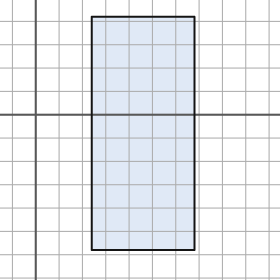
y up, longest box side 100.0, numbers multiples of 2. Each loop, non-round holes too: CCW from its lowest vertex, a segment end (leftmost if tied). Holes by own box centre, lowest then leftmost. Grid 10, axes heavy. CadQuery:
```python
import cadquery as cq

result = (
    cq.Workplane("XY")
    .moveTo(24.0, -58.0)
    .lineTo(68.0, -58.0)
    .lineTo(68.0, 42.0)
    .lineTo(24.0, 42.0)
    .close()
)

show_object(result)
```